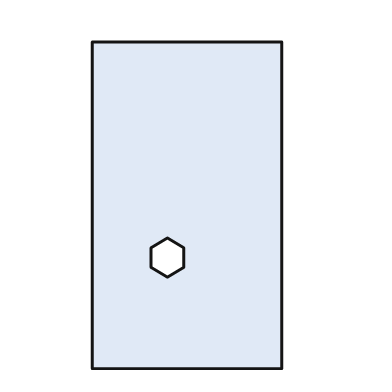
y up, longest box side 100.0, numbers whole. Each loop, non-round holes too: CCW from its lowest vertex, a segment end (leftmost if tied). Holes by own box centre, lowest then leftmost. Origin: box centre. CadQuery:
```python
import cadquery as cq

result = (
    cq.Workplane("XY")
    .moveTo(-29.0, -50.0)
    .lineTo(29.0, -50.0)
    .lineTo(29.0, 50.0)
    .lineTo(-29.0, 50.0)
    .close()
    .moveTo(-6.0, -22.0)
    .lineTo(-1.0, -19.0)
    .lineTo(-1.0, -13.0)
    .lineTo(-6.0, -10.0)
    .lineTo(-11.0, -13.0)
    .lineTo(-11.0, -19.0)
    .close()
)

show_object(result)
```